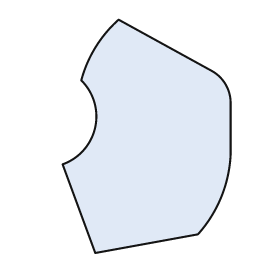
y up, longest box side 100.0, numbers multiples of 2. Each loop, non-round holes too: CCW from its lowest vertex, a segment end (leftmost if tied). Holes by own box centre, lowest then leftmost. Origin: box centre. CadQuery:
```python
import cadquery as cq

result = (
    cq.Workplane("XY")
    .moveTo(-22.0, -50.0)
    .lineTo(22.0, -42.0)
    .threePointArc((32.0, -26.0), (36.0, -8.0))
    .lineTo(36.0, 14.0)
    .threePointArc((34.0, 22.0), (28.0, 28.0))
    .lineTo(-12.0, 50.0)
    .threePointArc((-22.0, 38.0), (-28.0, 24.0))
    .threePointArc((-22.0, 4.0), (-36.0, -12.0))
    .close()
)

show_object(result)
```